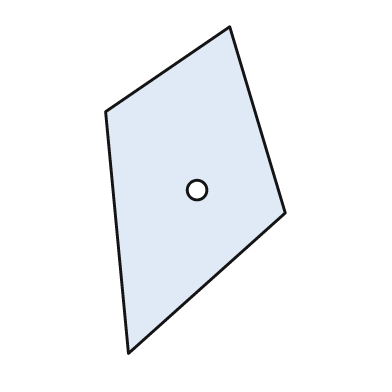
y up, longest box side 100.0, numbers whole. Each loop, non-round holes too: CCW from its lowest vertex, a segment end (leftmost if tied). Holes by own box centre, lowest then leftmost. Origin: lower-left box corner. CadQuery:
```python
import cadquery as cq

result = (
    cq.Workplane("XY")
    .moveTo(7.0, 0.0)
    .lineTo(55.0, 43.0)
    .lineTo(38.0, 100.0)
    .lineTo(0.0, 74.0)
    .close()
    .moveTo(28.0, 50.0)
    .circle(3.0)
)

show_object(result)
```